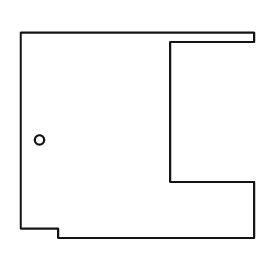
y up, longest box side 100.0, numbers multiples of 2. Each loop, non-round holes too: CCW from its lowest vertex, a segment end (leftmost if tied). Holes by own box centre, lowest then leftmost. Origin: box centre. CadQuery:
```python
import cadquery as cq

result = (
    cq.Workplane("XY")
    .moveTo(-34.0, -44.0)
    .lineTo(50.0, -44.0)
    .lineTo(50.0, -20.0)
    .lineTo(14.0, -20.0)
    .lineTo(14.0, 40.0)
    .lineTo(50.0, 40.0)
    .lineTo(50.0, 44.0)
    .lineTo(-50.0, 44.0)
    .lineTo(-50.0, -40.0)
    .lineTo(-34.0, -40.0)
    .close()
    .moveTo(-42.0, -2.0)
    .circle(2.0)
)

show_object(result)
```